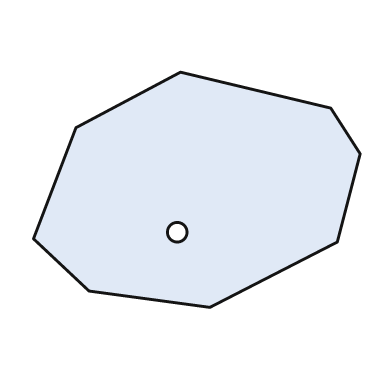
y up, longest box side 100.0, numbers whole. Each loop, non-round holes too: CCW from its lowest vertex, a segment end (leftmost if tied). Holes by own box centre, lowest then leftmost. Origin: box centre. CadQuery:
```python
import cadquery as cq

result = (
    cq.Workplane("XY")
    .moveTo(4.0, -36.0)
    .lineTo(43.0, -16.0)
    .lineTo(50.0, 11.0)
    .lineTo(41.0, 25.0)
    .lineTo(-5.0, 36.0)
    .lineTo(-37.0, 19.0)
    .lineTo(-50.0, -15.0)
    .lineTo(-33.0, -31.0)
    .close()
    .moveTo(-6.0, -13.0)
    .circle(3.0)
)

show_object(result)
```